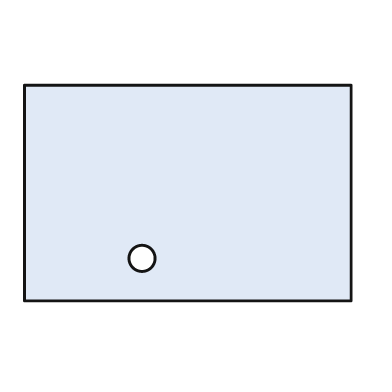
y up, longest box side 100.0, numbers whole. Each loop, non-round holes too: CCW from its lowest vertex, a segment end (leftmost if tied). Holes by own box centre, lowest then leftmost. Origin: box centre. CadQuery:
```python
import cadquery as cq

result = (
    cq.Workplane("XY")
    .moveTo(-50.0, -33.0)
    .lineTo(50.0, -33.0)
    .lineTo(50.0, 33.0)
    .lineTo(-50.0, 33.0)
    .close()
    .moveTo(-14.0, -20.0)
    .circle(4.0)
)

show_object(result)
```